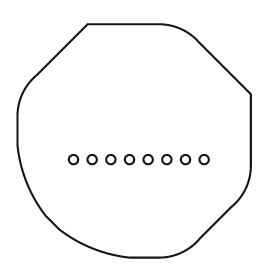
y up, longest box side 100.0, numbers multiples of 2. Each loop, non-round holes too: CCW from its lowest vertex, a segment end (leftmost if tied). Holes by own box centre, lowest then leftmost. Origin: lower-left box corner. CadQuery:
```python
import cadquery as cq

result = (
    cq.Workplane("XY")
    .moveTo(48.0, 0.0)
    .lineTo(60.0, 0.0)
    .threePointArc((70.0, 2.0), (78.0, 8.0))
    .lineTo(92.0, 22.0)
    .threePointArc((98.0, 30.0), (100.0, 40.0))
    .lineTo(100.0, 70.0)
    .lineTo(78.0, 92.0)
    .threePointArc((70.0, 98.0), (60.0, 100.0))
    .lineTo(30.0, 100.0)
    .lineTo(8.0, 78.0)
    .threePointArc((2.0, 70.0), (0.0, 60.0))
    .lineTo(0.0, 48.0)
    .threePointArc((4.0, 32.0), (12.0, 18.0))
    .lineTo(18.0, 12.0)
    .threePointArc((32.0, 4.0), (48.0, 0.0))
    .close()
    .moveTo(24.0, 42.0)
    .circle(2.0)
    .moveTo(32.0, 42.0)
    .circle(2.0)
    .moveTo(40.0, 42.0)
    .circle(2.0)
    .moveTo(48.0, 42.0)
    .circle(2.0)
    .moveTo(56.0, 42.0)
    .circle(2.0)
    .moveTo(64.0, 42.0)
    .circle(2.0)
    .moveTo(72.0, 42.0)
    .circle(2.0)
    .moveTo(80.0, 42.0)
    .circle(2.0)
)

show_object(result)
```